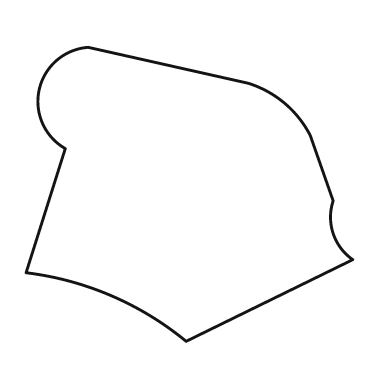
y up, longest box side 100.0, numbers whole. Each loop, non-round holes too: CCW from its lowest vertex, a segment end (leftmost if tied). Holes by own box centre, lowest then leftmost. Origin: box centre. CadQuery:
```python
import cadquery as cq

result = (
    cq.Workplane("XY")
    .moveTo(-1.0, -45.0)
    .lineTo(50.0, -20.0)
    .threePointArc((44.0, -12.0), (44.0, -2.0))
    .lineTo(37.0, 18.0)
    .threePointArc((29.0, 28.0), (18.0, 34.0))
    .lineTo(-31.0, 45.0)
    .threePointArc((-46.0, 32.0), (-38.0, 14.0))
    .lineTo(-50.0, -24.0)
    .threePointArc((-24.0, -31.0), (-1.0, -45.0))
    .close()
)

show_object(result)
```